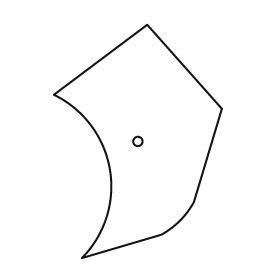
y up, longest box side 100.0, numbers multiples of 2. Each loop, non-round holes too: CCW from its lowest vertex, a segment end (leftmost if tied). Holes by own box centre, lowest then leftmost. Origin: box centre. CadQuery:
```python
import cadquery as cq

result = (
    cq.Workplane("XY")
    .moveTo(-24.0, -50.0)
    .lineTo(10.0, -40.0)
    .threePointArc((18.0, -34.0), (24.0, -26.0))
    .lineTo(36.0, 14.0)
    .lineTo(4.0, 50.0)
    .lineTo(-36.0, 20.0)
    .threePointArc((-12.0, -12.0), (-24.0, -50.0))
    .close()
    .moveTo(0.0, 0.0)
    .circle(2.0)
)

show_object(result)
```